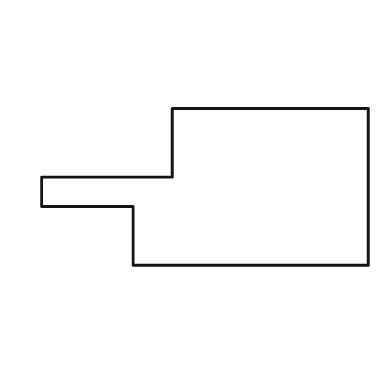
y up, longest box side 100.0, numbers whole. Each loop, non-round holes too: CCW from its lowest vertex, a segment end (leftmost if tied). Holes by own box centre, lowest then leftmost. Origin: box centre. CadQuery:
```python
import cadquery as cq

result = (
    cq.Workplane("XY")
    .moveTo(-22.0, -24.0)
    .lineTo(50.0, -24.0)
    .lineTo(50.0, 24.0)
    .lineTo(-10.0, 24.0)
    .lineTo(-10.0, 3.0)
    .lineTo(-50.0, 3.0)
    .lineTo(-50.0, -6.0)
    .lineTo(-22.0, -6.0)
    .close()
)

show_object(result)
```